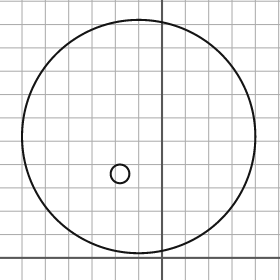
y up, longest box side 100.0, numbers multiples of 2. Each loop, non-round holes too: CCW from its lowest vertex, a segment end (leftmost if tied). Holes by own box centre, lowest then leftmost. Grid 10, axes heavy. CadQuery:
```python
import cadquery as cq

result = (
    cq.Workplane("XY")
    .moveTo(-10.0, 52.0)
    .circle(50.0)
    .moveTo(-18.0, 36.0)
    .circle(4.0)
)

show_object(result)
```